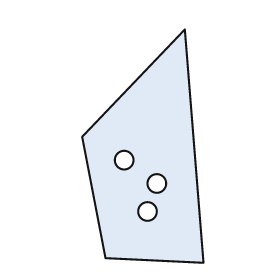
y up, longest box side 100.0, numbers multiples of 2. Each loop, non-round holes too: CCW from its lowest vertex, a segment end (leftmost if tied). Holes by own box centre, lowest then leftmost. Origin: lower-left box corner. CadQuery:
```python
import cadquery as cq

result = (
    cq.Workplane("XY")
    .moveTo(52.0, 0.0)
    .lineTo(44.0, 100.0)
    .lineTo(0.0, 54.0)
    .lineTo(10.0, 2.0)
    .close()
    .moveTo(28.0, 22.0)
    .circle(4.0)
    .moveTo(32.0, 34.0)
    .circle(4.0)
    .moveTo(18.0, 44.0)
    .circle(4.0)
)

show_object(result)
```